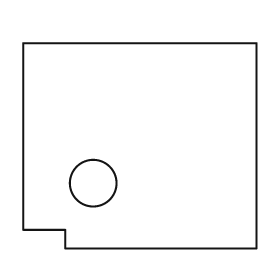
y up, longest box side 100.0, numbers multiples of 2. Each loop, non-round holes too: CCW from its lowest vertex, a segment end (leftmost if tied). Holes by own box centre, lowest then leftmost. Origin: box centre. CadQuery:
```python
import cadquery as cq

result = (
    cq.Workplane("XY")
    .moveTo(-32.0, -44.0)
    .lineTo(50.0, -44.0)
    .lineTo(50.0, 44.0)
    .lineTo(-50.0, 44.0)
    .lineTo(-50.0, -36.0)
    .lineTo(-32.0, -36.0)
    .close()
    .moveTo(-20.0, -16.0)
    .circle(10.0)
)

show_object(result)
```